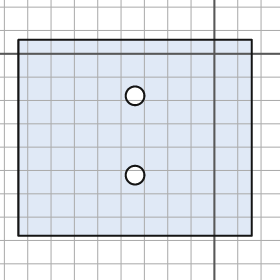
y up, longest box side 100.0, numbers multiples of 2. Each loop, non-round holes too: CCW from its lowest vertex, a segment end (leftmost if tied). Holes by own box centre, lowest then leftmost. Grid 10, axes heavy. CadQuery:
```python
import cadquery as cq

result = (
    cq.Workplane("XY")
    .moveTo(-84.0, -78.0)
    .lineTo(16.0, -78.0)
    .lineTo(16.0, 6.0)
    .lineTo(-84.0, 6.0)
    .close()
    .moveTo(-34.0, -52.0)
    .circle(4.0)
    .moveTo(-34.0, -18.0)
    .circle(4.0)
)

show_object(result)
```